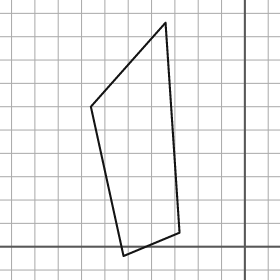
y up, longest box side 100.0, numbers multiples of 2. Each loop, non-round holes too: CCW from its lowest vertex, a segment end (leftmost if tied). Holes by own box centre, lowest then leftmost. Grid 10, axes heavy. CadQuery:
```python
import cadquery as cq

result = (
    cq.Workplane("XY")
    .moveTo(-52.0, -4.0)
    .lineTo(-28.0, 6.0)
    .lineTo(-34.0, 96.0)
    .lineTo(-66.0, 60.0)
    .close()
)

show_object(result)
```